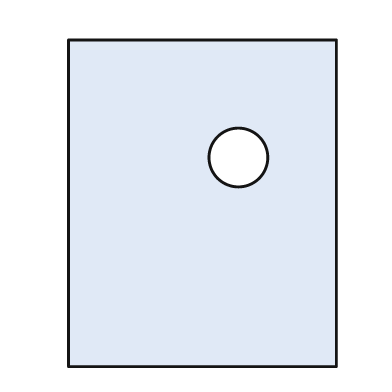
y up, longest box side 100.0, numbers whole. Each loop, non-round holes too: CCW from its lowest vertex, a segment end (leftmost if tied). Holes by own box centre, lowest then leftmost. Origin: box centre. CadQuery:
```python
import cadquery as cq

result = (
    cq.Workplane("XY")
    .moveTo(-41.0, -50.0)
    .lineTo(41.0, -50.0)
    .lineTo(41.0, 50.0)
    .lineTo(-41.0, 50.0)
    .close()
    .moveTo(11.0, 14.0)
    .circle(9.0)
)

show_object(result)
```